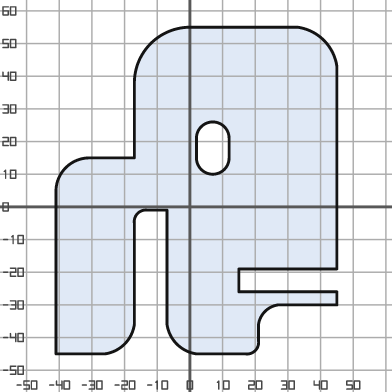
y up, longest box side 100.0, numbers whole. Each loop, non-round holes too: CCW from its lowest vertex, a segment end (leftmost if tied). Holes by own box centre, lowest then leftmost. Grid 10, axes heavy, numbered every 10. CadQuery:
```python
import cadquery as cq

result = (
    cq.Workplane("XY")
    .moveTo(-41.0, -45.0)
    .lineTo(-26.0, -45.0)
    .threePointArc((-20.0, -42.0), (-17.0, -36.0))
    .lineTo(-17.0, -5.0)
    .threePointArc((-16.0, -2.0), (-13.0, -1.0))
    .lineTo(-7.0, -1.0)
    .lineTo(-7.0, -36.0)
    .threePointArc((-4.0, -42.0), (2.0, -45.0))
    .lineTo(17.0, -45.0)
    .threePointArc((20.0, -44.0), (21.0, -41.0))
    .lineTo(21.0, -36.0)
    .threePointArc((23.0, -32.0), (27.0, -30.0))
    .lineTo(45.0, -30.0)
    .lineTo(45.0, -26.0)
    .lineTo(15.0, -26.0)
    .lineTo(15.0, -19.0)
    .lineTo(45.0, -19.0)
    .lineTo(45.0, 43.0)
    .threePointArc((41.0, 51.0), (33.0, 55.0))
    .lineTo(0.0, 55.0)
    .threePointArc((-12.0, 50.0), (-17.0, 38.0))
    .lineTo(-17.0, 15.0)
    .lineTo(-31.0, 15.0)
    .threePointArc((-38.0, 12.0), (-41.0, 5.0))
    .close()
    .moveTo(2.0, 15.0)
    .threePointArc((7.0, 10.0), (12.0, 15.0))
    .lineTo(12.0, 21.0)
    .threePointArc((7.0, 26.0), (2.0, 21.0))
    .close()
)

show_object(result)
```